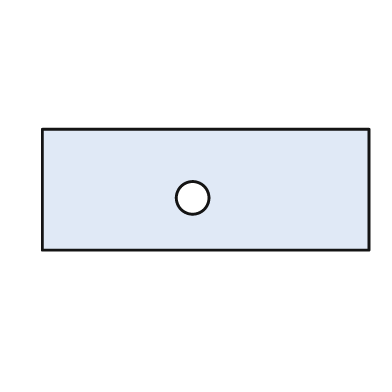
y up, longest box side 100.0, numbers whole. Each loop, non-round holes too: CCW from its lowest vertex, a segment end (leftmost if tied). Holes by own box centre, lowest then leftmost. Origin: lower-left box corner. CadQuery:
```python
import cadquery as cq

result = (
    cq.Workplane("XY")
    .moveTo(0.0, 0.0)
    .lineTo(100.0, 0.0)
    .lineTo(100.0, 37.0)
    .lineTo(0.0, 37.0)
    .close()
    .moveTo(46.0, 16.0)
    .circle(5.0)
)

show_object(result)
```